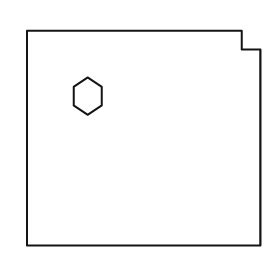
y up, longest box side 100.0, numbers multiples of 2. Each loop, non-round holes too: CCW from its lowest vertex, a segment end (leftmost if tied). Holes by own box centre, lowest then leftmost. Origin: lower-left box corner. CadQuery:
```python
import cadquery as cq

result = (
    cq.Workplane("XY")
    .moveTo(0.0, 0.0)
    .lineTo(100.0, 0.0)
    .lineTo(100.0, 84.0)
    .lineTo(92.0, 84.0)
    .lineTo(92.0, 92.0)
    .lineTo(0.0, 92.0)
    .close()
    .moveTo(26.0, 56.0)
    .lineTo(32.0, 60.0)
    .lineTo(32.0, 68.0)
    .lineTo(26.0, 72.0)
    .lineTo(20.0, 68.0)
    .lineTo(20.0, 60.0)
    .close()
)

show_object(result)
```